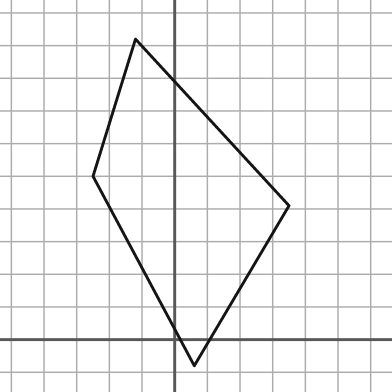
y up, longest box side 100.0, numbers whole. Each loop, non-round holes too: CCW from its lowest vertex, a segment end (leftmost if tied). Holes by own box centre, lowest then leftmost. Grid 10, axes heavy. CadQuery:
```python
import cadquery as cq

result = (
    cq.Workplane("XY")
    .moveTo(6.0, -8.0)
    .lineTo(35.0, 41.0)
    .lineTo(-12.0, 92.0)
    .lineTo(-25.0, 50.0)
    .close()
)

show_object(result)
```